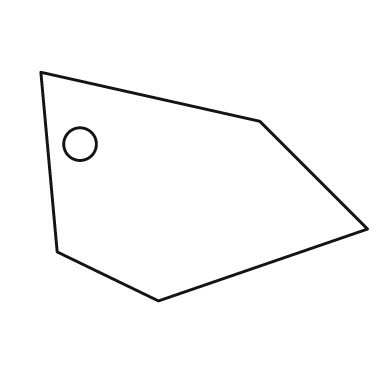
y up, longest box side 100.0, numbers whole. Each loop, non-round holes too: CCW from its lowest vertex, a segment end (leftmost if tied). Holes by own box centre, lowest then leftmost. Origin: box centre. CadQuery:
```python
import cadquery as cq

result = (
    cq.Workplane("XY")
    .moveTo(-14.0, -35.0)
    .lineTo(50.0, -13.0)
    .lineTo(17.0, 20.0)
    .lineTo(-50.0, 35.0)
    .lineTo(-45.0, -20.0)
    .close()
    .moveTo(-38.0, 13.0)
    .circle(5.0)
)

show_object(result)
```